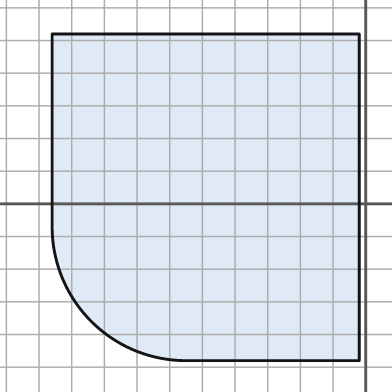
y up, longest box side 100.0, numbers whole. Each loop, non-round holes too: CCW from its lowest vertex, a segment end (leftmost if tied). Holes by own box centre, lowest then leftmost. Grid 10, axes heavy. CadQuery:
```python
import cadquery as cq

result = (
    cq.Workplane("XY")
    .moveTo(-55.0, -48.0)
    .lineTo(-2.0, -48.0)
    .lineTo(-2.0, 52.0)
    .lineTo(-96.0, 52.0)
    .lineTo(-96.0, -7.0)
    .threePointArc((-84.0, -36.0), (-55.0, -48.0))
    .close()
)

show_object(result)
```